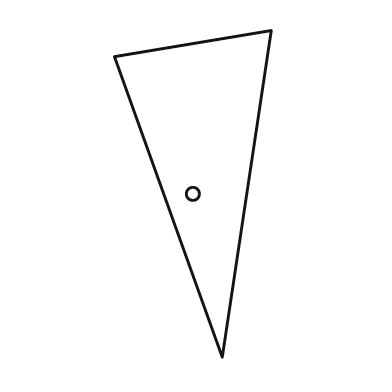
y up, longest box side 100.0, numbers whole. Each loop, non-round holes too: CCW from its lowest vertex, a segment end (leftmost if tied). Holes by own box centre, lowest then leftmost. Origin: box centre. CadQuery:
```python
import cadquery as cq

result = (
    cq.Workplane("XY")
    .moveTo(9.0, -50.0)
    .lineTo(24.0, 50.0)
    .lineTo(-24.0, 42.0)
    .close()
    .moveTo(0.0, 0.0)
    .circle(2.0)
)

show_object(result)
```